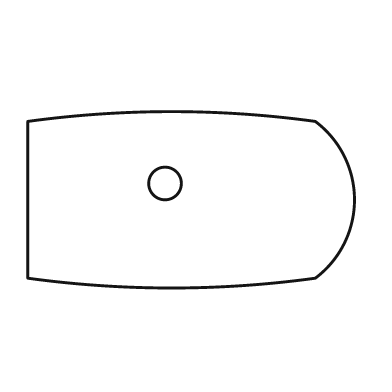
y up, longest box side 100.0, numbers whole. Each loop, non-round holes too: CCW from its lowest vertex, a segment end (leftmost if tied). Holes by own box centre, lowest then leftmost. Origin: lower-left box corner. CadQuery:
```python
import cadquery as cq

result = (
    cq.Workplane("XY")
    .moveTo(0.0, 3.0)
    .threePointArc((44.0, 0.0), (88.0, 3.0))
    .threePointArc((100.0, 27.0), (88.0, 51.0))
    .threePointArc((44.0, 54.0), (0.0, 51.0))
    .close()
    .moveTo(42.0, 32.0)
    .circle(5.0)
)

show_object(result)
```